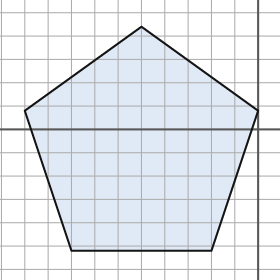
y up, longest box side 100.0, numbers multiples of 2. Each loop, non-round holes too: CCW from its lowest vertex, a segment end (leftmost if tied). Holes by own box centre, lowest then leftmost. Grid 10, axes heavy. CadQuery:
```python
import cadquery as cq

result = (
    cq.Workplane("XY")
    .moveTo(-80.0, -52.0)
    .lineTo(-20.0, -52.0)
    .lineTo(0.0, 8.0)
    .lineTo(-50.0, 44.0)
    .lineTo(-100.0, 8.0)
    .close()
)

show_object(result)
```